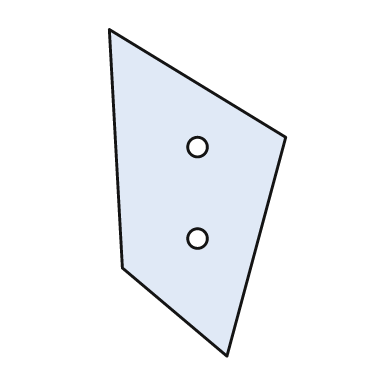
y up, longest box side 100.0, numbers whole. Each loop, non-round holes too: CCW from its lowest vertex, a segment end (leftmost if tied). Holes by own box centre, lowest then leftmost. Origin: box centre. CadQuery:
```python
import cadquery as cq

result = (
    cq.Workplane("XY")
    .moveTo(9.0, -50.0)
    .lineTo(27.0, 17.0)
    .lineTo(-27.0, 50.0)
    .lineTo(-23.0, -23.0)
    .close()
    .moveTo(0.0, -14.0)
    .circle(3.0)
    .moveTo(0.0, 14.0)
    .circle(3.0)
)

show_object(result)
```